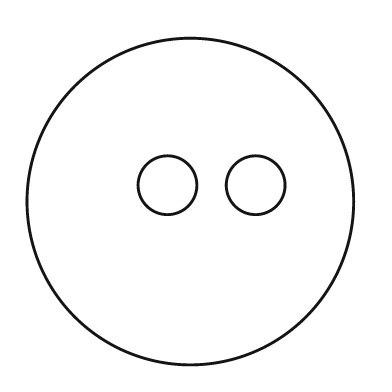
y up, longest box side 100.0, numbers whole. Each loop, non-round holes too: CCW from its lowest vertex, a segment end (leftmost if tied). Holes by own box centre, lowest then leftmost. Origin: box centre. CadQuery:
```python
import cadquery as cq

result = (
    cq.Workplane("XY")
    .moveTo(0.0, 0.0)
    .circle(50.0)
    .moveTo(-7.0, 5.0)
    .circle(9.0)
    .moveTo(20.0, 5.0)
    .circle(9.0)
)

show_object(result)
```